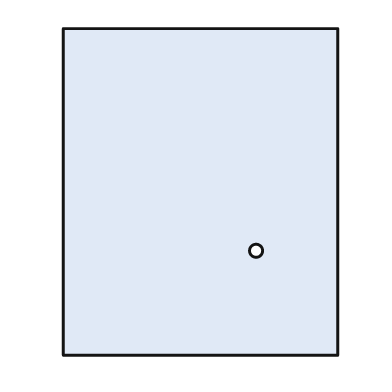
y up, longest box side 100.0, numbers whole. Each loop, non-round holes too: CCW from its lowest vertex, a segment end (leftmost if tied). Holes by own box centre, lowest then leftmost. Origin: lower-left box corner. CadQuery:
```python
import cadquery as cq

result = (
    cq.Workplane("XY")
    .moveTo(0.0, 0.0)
    .lineTo(84.0, 0.0)
    .lineTo(84.0, 100.0)
    .lineTo(0.0, 100.0)
    .close()
    .moveTo(59.0, 32.0)
    .circle(2.0)
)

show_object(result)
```